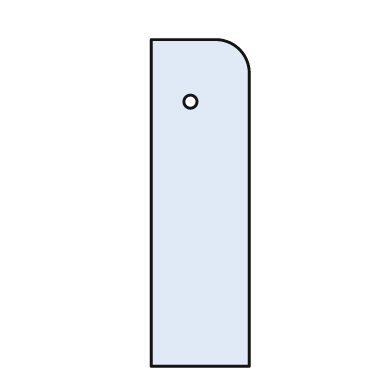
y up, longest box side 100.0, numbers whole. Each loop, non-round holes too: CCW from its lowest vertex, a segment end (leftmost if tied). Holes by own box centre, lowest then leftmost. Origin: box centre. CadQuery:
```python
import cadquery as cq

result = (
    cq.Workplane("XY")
    .moveTo(-15.0, -50.0)
    .lineTo(15.0, -50.0)
    .lineTo(15.0, 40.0)
    .threePointArc((12.0, 47.0), (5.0, 50.0))
    .lineTo(-15.0, 50.0)
    .close()
    .moveTo(-3.0, 31.0)
    .circle(2.0)
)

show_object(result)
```